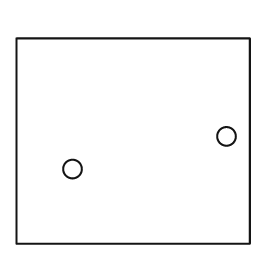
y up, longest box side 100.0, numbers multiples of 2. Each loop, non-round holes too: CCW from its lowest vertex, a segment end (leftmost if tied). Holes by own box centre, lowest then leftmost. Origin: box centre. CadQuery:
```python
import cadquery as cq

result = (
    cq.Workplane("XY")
    .moveTo(-50.0, -44.0)
    .lineTo(50.0, -44.0)
    .lineTo(50.0, 44.0)
    .lineTo(-50.0, 44.0)
    .close()
    .moveTo(-26.0, -12.0)
    .circle(4.0)
    .moveTo(40.0, 2.0)
    .circle(4.0)
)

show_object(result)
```